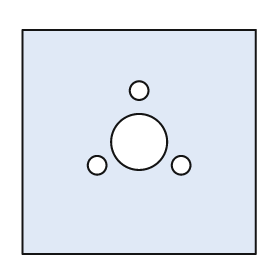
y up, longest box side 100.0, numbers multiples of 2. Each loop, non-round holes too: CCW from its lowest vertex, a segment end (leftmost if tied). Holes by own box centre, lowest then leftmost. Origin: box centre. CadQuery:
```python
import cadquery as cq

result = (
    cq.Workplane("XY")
    .moveTo(-50.0, -48.0)
    .lineTo(50.0, -48.0)
    .lineTo(50.0, 48.0)
    .lineTo(-50.0, 48.0)
    .close()
    .moveTo(-18.0, -10.0)
    .circle(4.0)
    .moveTo(18.0, -10.0)
    .circle(4.0)
    .moveTo(0.0, 0.0)
    .circle(12.0)
    .moveTo(0.0, 22.0)
    .circle(4.0)
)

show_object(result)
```